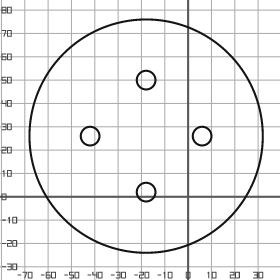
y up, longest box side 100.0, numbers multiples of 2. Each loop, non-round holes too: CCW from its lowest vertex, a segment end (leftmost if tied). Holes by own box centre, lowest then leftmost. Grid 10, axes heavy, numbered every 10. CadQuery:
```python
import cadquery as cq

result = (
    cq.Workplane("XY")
    .moveTo(-18.0, 26.0)
    .circle(50.0)
    .moveTo(-18.0, 2.0)
    .circle(4.0)
    .moveTo(-42.0, 26.0)
    .circle(4.0)
    .moveTo(6.0, 26.0)
    .circle(4.0)
    .moveTo(-18.0, 50.0)
    .circle(4.0)
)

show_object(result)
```